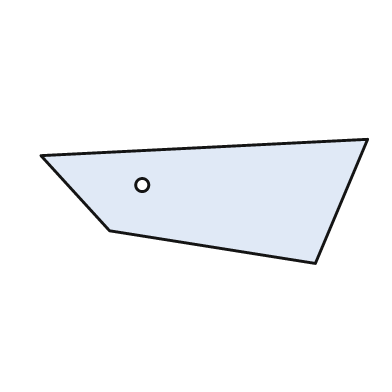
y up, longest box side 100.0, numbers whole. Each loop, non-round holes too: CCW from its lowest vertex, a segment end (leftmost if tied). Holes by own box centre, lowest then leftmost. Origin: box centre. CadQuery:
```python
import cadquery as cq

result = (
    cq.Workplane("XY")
    .moveTo(34.0, -19.0)
    .lineTo(50.0, 19.0)
    .lineTo(-50.0, 14.0)
    .lineTo(-29.0, -9.0)
    .close()
    .moveTo(-19.0, 5.0)
    .circle(2.0)
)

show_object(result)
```